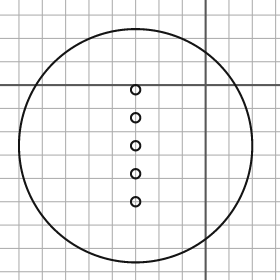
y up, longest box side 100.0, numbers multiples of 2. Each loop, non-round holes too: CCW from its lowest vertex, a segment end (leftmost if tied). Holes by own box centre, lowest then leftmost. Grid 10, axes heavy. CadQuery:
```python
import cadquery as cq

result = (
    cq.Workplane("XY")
    .moveTo(-30.0, -26.0)
    .circle(50.0)
    .moveTo(-30.0, -50.0)
    .circle(2.0)
    .moveTo(-30.0, -38.0)
    .circle(2.0)
    .moveTo(-30.0, -26.0)
    .circle(2.0)
    .moveTo(-30.0, -14.0)
    .circle(2.0)
    .moveTo(-30.0, -2.0)
    .circle(2.0)
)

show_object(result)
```